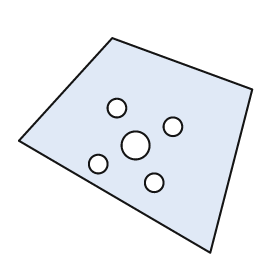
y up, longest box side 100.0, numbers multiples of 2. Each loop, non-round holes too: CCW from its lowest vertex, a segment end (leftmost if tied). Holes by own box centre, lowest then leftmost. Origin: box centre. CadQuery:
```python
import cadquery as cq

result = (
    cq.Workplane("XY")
    .moveTo(32.0, -46.0)
    .lineTo(50.0, 24.0)
    .lineTo(-10.0, 46.0)
    .lineTo(-50.0, 2.0)
    .close()
    .moveTo(8.0, -16.0)
    .circle(4.0)
    .moveTo(-16.0, -8.0)
    .circle(4.0)
    .moveTo(0.0, 0.0)
    .circle(6.0)
    .moveTo(16.0, 8.0)
    .circle(4.0)
    .moveTo(-8.0, 16.0)
    .circle(4.0)
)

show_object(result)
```